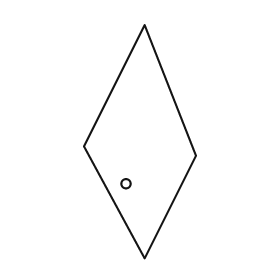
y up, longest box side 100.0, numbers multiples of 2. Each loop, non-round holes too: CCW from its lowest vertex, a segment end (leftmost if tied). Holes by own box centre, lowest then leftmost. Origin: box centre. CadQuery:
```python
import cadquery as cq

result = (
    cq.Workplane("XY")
    .moveTo(2.0, -50.0)
    .lineTo(24.0, -6.0)
    .lineTo(2.0, 50.0)
    .lineTo(-24.0, -2.0)
    .close()
    .moveTo(-6.0, -18.0)
    .circle(2.0)
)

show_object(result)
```